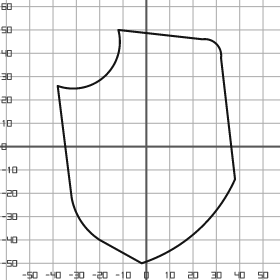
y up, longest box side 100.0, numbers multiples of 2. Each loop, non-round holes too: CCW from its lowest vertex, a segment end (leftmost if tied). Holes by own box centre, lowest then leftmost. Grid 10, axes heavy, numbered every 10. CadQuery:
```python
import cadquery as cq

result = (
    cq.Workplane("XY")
    .moveTo(-2.0, -50.0)
    .threePointArc((22.0, -36.0), (38.0, -14.0))
    .lineTo(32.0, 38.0)
    .threePointArc((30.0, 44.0), (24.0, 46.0))
    .lineTo(-12.0, 50.0)
    .threePointArc((-18.0, 30.0), (-38.0, 26.0))
    .lineTo(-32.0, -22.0)
    .threePointArc((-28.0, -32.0), (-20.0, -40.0))
    .close()
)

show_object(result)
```